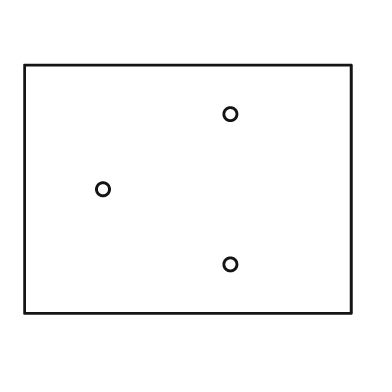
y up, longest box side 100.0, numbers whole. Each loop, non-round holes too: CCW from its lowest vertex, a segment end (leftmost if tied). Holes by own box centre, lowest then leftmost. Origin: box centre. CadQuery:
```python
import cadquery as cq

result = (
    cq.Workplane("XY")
    .moveTo(-50.0, -38.0)
    .lineTo(50.0, -38.0)
    .lineTo(50.0, 38.0)
    .lineTo(-50.0, 38.0)
    .close()
    .moveTo(13.0, -23.0)
    .circle(2.0)
    .moveTo(-26.0, 0.0)
    .circle(2.0)
    .moveTo(13.0, 23.0)
    .circle(2.0)
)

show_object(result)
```